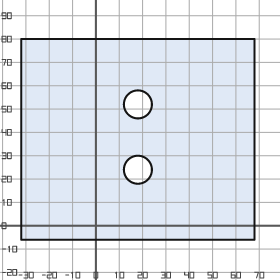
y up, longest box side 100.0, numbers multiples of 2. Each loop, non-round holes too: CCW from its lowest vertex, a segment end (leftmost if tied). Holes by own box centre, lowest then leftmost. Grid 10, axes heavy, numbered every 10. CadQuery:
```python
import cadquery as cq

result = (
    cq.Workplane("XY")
    .moveTo(-32.0, -6.0)
    .lineTo(68.0, -6.0)
    .lineTo(68.0, 80.0)
    .lineTo(-32.0, 80.0)
    .close()
    .moveTo(18.0, 24.0)
    .circle(6.0)
    .moveTo(18.0, 52.0)
    .circle(6.0)
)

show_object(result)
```